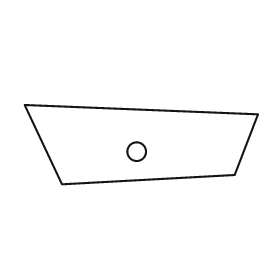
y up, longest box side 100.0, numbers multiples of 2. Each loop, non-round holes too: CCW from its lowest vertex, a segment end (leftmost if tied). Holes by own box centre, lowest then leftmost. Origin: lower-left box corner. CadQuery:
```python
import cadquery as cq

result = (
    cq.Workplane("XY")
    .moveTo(16.0, 0.0)
    .lineTo(90.0, 4.0)
    .lineTo(100.0, 30.0)
    .lineTo(0.0, 34.0)
    .close()
    .moveTo(48.0, 14.0)
    .circle(4.0)
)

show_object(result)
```